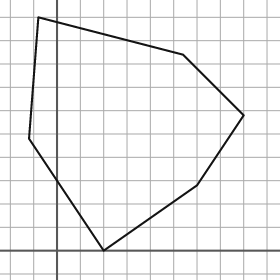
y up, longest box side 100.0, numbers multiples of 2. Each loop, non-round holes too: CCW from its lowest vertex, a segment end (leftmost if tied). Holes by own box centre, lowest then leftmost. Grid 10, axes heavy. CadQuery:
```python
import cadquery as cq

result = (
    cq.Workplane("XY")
    .moveTo(20.0, 0.0)
    .lineTo(60.0, 28.0)
    .lineTo(80.0, 58.0)
    .lineTo(54.0, 84.0)
    .lineTo(-8.0, 100.0)
    .lineTo(-12.0, 48.0)
    .close()
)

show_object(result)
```